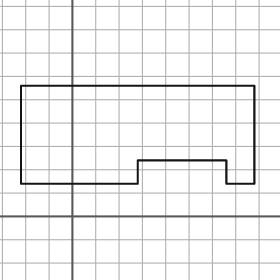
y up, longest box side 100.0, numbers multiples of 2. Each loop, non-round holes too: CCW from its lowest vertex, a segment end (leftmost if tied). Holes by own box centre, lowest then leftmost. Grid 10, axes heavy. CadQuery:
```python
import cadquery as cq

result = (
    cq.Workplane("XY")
    .moveTo(-22.0, 14.0)
    .lineTo(28.0, 14.0)
    .lineTo(28.0, 24.0)
    .lineTo(66.0, 24.0)
    .lineTo(66.0, 14.0)
    .lineTo(78.0, 14.0)
    .lineTo(78.0, 56.0)
    .lineTo(-22.0, 56.0)
    .close()
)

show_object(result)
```